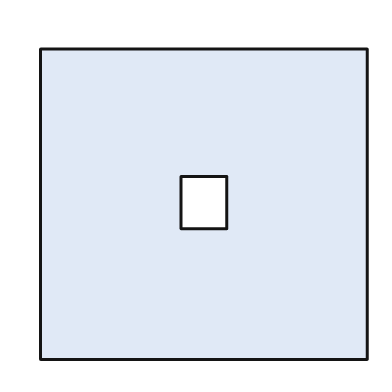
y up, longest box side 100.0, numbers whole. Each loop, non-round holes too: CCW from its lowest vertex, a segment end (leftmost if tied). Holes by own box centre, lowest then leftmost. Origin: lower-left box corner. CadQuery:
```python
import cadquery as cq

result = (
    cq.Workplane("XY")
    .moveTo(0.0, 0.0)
    .lineTo(100.0, 0.0)
    .lineTo(100.0, 95.0)
    .lineTo(0.0, 95.0)
    .close()
    .moveTo(43.0, 40.0)
    .lineTo(57.0, 40.0)
    .lineTo(57.0, 56.0)
    .lineTo(43.0, 56.0)
    .close()
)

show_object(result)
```